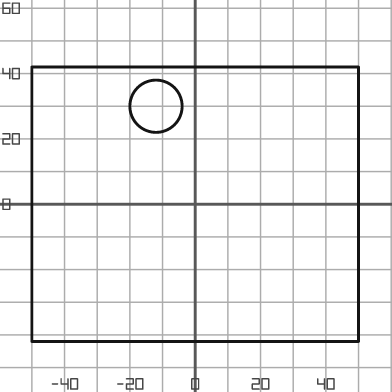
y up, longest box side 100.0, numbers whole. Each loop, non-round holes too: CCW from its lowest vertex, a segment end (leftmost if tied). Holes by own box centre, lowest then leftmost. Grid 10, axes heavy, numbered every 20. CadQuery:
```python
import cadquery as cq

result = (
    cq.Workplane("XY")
    .moveTo(-50.0, -42.0)
    .lineTo(50.0, -42.0)
    .lineTo(50.0, 42.0)
    .lineTo(-50.0, 42.0)
    .close()
    .moveTo(-12.0, 30.0)
    .circle(8.0)
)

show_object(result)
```